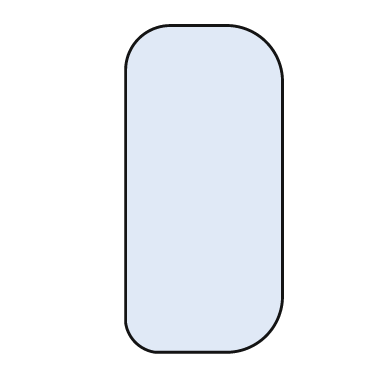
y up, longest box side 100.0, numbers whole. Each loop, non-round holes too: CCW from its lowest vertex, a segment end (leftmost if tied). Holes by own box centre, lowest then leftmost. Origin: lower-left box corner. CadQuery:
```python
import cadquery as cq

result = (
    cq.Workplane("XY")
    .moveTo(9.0, 0.0)
    .lineTo(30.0, 0.0)
    .threePointArc((43.0, 5.0), (48.0, 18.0))
    .lineTo(48.0, 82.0)
    .threePointArc((43.0, 95.0), (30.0, 100.0))
    .lineTo(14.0, 100.0)
    .threePointArc((4.0, 96.0), (0.0, 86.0))
    .lineTo(0.0, 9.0)
    .threePointArc((3.0, 3.0), (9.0, 0.0))
    .close()
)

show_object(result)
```